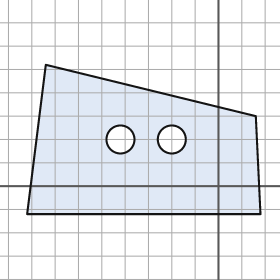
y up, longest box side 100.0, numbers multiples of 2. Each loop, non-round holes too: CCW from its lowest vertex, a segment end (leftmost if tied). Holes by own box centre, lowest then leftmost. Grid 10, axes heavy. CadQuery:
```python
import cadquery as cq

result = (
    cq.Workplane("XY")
    .moveTo(-82.0, -12.0)
    .lineTo(18.0, -12.0)
    .lineTo(16.0, 30.0)
    .lineTo(-74.0, 52.0)
    .close()
    .moveTo(-42.0, 20.0)
    .circle(6.0)
    .moveTo(-20.0, 20.0)
    .circle(6.0)
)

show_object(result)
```